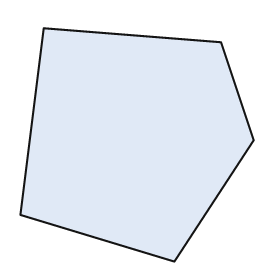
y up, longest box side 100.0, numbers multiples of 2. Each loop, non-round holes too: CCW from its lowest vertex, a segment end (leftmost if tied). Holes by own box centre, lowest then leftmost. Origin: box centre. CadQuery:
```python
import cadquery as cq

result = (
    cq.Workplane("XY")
    .moveTo(16.0, -50.0)
    .lineTo(50.0, 2.0)
    .lineTo(36.0, 44.0)
    .lineTo(-40.0, 50.0)
    .lineTo(-50.0, -30.0)
    .close()
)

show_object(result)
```